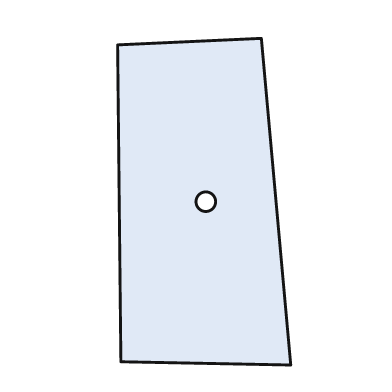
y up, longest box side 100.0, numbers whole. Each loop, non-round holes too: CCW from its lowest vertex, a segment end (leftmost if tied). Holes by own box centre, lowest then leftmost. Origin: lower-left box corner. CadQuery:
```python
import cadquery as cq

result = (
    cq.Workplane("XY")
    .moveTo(53.0, 0.0)
    .lineTo(44.0, 100.0)
    .lineTo(0.0, 98.0)
    .lineTo(1.0, 1.0)
    .close()
    .moveTo(27.0, 50.0)
    .circle(3.0)
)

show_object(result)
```